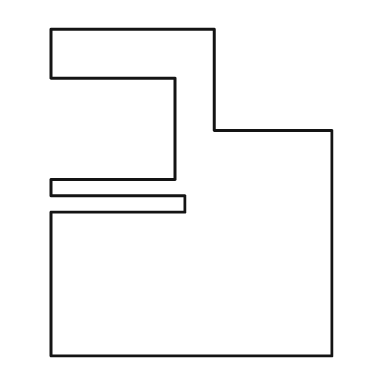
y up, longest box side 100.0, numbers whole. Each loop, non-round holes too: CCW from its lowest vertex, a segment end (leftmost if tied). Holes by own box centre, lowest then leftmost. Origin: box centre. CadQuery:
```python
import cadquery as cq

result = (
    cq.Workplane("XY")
    .moveTo(-43.0, -50.0)
    .lineTo(43.0, -50.0)
    .lineTo(43.0, 19.0)
    .lineTo(7.0, 19.0)
    .lineTo(7.0, 50.0)
    .lineTo(-43.0, 50.0)
    .lineTo(-43.0, 35.0)
    .lineTo(-5.0, 35.0)
    .lineTo(-5.0, 4.0)
    .lineTo(-43.0, 4.0)
    .lineTo(-43.0, -1.0)
    .lineTo(-2.0, -1.0)
    .lineTo(-2.0, -6.0)
    .lineTo(-43.0, -6.0)
    .close()
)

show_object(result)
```